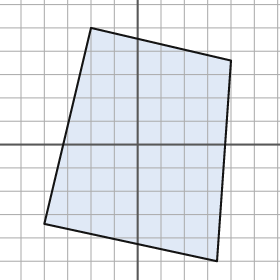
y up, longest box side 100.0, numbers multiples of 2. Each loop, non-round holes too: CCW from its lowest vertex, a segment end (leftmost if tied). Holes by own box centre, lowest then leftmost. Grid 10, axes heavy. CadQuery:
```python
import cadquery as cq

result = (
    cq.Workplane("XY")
    .moveTo(34.0, -50.0)
    .lineTo(40.0, 36.0)
    .lineTo(-20.0, 50.0)
    .lineTo(-40.0, -34.0)
    .close()
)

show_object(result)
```